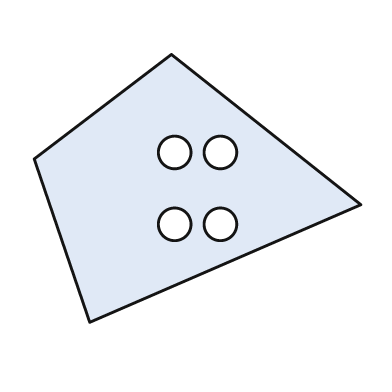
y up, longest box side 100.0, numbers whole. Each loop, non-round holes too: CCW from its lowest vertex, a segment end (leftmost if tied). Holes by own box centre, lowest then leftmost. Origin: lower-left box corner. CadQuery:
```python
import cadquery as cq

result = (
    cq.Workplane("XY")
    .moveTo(17.0, 0.0)
    .lineTo(100.0, 36.0)
    .lineTo(42.0, 82.0)
    .lineTo(0.0, 50.0)
    .close()
    .moveTo(43.0, 30.0)
    .circle(5.0)
    .moveTo(57.0, 30.0)
    .circle(5.0)
    .moveTo(43.0, 52.0)
    .circle(5.0)
    .moveTo(57.0, 52.0)
    .circle(5.0)
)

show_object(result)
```